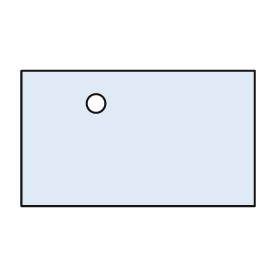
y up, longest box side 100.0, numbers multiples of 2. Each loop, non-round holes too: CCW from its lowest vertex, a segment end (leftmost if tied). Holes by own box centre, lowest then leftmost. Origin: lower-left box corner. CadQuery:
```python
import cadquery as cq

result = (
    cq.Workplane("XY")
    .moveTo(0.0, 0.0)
    .lineTo(100.0, 0.0)
    .lineTo(100.0, 58.0)
    .lineTo(0.0, 58.0)
    .close()
    .moveTo(32.0, 44.0)
    .circle(4.0)
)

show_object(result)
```